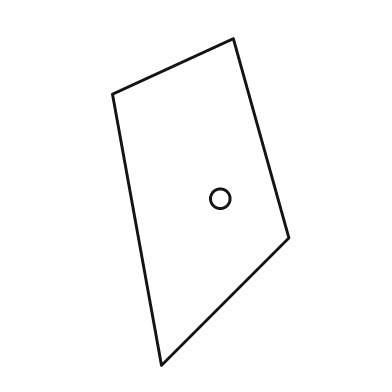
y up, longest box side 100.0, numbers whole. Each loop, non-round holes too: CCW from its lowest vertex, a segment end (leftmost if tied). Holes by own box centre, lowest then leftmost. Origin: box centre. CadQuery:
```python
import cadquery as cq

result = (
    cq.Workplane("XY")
    .moveTo(-12.0, -50.0)
    .lineTo(27.0, -11.0)
    .lineTo(10.0, 50.0)
    .lineTo(-27.0, 33.0)
    .close()
    .moveTo(6.0, 1.0)
    .circle(3.0)
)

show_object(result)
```